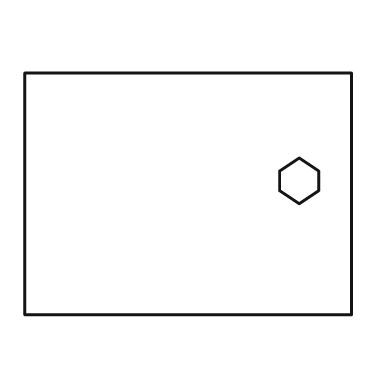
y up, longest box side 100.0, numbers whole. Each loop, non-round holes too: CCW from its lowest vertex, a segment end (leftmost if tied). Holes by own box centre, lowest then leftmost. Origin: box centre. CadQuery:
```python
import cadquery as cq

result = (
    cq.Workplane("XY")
    .moveTo(-50.0, -37.0)
    .lineTo(50.0, -37.0)
    .lineTo(50.0, 37.0)
    .lineTo(-50.0, 37.0)
    .close()
    .moveTo(34.0, -3.0)
    .lineTo(40.0, 1.0)
    .lineTo(40.0, 7.0)
    .lineTo(34.0, 11.0)
    .lineTo(28.0, 7.0)
    .lineTo(28.0, 1.0)
    .close()
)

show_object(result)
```